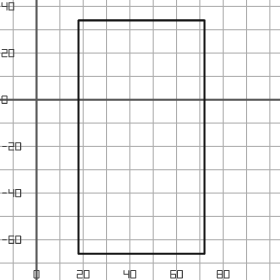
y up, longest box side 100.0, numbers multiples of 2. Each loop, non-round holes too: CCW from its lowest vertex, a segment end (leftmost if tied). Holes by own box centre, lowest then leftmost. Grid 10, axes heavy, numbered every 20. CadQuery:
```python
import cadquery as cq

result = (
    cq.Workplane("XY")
    .moveTo(18.0, -66.0)
    .lineTo(72.0, -66.0)
    .lineTo(72.0, 34.0)
    .lineTo(18.0, 34.0)
    .close()
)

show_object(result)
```